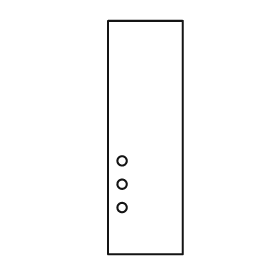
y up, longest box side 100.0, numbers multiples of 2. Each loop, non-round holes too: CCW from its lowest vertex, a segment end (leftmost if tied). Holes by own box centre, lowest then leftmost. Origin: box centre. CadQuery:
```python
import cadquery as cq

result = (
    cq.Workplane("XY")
    .moveTo(-16.0, -50.0)
    .lineTo(16.0, -50.0)
    .lineTo(16.0, 50.0)
    .lineTo(-16.0, 50.0)
    .close()
    .moveTo(-10.0, -30.0)
    .circle(2.0)
    .moveTo(-10.0, -20.0)
    .circle(2.0)
    .moveTo(-10.0, -10.0)
    .circle(2.0)
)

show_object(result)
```